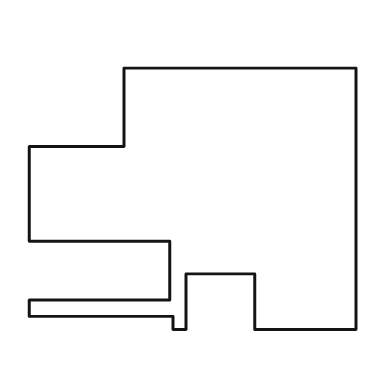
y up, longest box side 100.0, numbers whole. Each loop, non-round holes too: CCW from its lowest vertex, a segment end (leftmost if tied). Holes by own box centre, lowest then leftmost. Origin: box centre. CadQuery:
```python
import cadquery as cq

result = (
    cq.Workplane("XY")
    .moveTo(-6.0, -40.0)
    .lineTo(-2.0, -40.0)
    .lineTo(-2.0, -23.0)
    .lineTo(19.0, -23.0)
    .lineTo(19.0, -40.0)
    .lineTo(50.0, -40.0)
    .lineTo(50.0, 40.0)
    .lineTo(-21.0, 40.0)
    .lineTo(-21.0, 16.0)
    .lineTo(-50.0, 16.0)
    .lineTo(-50.0, -13.0)
    .lineTo(-7.0, -13.0)
    .lineTo(-7.0, -31.0)
    .lineTo(-50.0, -31.0)
    .lineTo(-50.0, -36.0)
    .lineTo(-6.0, -36.0)
    .close()
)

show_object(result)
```